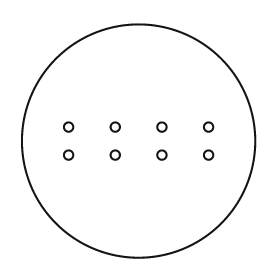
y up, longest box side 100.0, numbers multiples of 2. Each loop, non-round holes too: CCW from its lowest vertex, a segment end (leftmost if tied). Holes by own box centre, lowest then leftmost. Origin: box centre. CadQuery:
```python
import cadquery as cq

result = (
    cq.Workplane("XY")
    .moveTo(0.0, 0.0)
    .circle(50.0)
    .moveTo(-30.0, -6.0)
    .circle(2.0)
    .moveTo(-10.0, -6.0)
    .circle(2.0)
    .moveTo(10.0, -6.0)
    .circle(2.0)
    .moveTo(30.0, -6.0)
    .circle(2.0)
    .moveTo(-30.0, 6.0)
    .circle(2.0)
    .moveTo(-10.0, 6.0)
    .circle(2.0)
    .moveTo(10.0, 6.0)
    .circle(2.0)
    .moveTo(30.0, 6.0)
    .circle(2.0)
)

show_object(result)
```